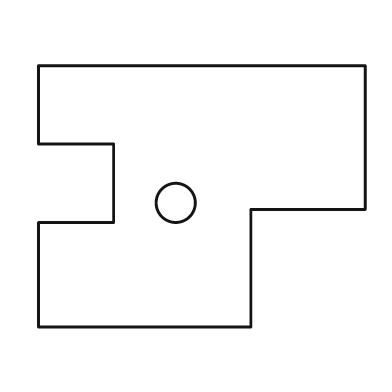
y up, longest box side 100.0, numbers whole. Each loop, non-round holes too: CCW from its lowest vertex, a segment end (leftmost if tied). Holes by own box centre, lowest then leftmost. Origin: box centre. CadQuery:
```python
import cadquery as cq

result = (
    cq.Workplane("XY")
    .moveTo(-50.0, -40.0)
    .lineTo(15.0, -40.0)
    .lineTo(15.0, -4.0)
    .lineTo(50.0, -4.0)
    .lineTo(50.0, 40.0)
    .lineTo(-50.0, 40.0)
    .lineTo(-50.0, 16.0)
    .lineTo(-27.0, 16.0)
    .lineTo(-27.0, -8.0)
    .lineTo(-50.0, -8.0)
    .close()
    .moveTo(-8.0, -2.0)
    .circle(6.0)
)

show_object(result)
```